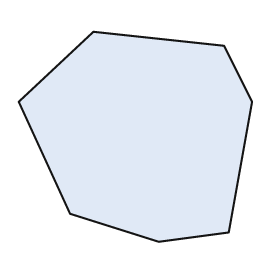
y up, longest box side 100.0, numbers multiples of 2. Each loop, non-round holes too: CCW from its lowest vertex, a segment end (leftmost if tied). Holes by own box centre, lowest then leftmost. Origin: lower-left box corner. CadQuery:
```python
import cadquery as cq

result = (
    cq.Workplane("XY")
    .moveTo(60.0, 0.0)
    .lineTo(90.0, 4.0)
    .lineTo(100.0, 60.0)
    .lineTo(88.0, 84.0)
    .lineTo(32.0, 90.0)
    .lineTo(0.0, 60.0)
    .lineTo(22.0, 12.0)
    .close()
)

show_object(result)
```